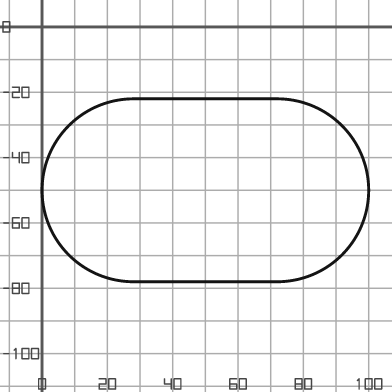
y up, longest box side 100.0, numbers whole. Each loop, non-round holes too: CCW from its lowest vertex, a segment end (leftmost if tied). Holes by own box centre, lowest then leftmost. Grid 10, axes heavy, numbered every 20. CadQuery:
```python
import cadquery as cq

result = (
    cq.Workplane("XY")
    .moveTo(28.0, -78.0)
    .lineTo(72.0, -78.0)
    .threePointArc((100.0, -50.0), (72.0, -22.0))
    .lineTo(28.0, -22.0)
    .threePointArc((0.0, -50.0), (28.0, -78.0))
    .close()
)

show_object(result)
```